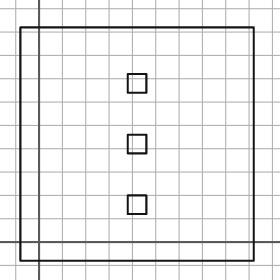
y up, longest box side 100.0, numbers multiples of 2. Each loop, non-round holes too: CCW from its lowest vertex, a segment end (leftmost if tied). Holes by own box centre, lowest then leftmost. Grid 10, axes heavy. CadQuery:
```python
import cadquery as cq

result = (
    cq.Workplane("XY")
    .moveTo(-8.0, -8.0)
    .lineTo(92.0, -8.0)
    .lineTo(92.0, 92.0)
    .lineTo(-8.0, 92.0)
    .close()
    .moveTo(38.0, 12.0)
    .lineTo(46.0, 12.0)
    .lineTo(46.0, 20.0)
    .lineTo(38.0, 20.0)
    .close()
    .moveTo(38.0, 38.0)
    .lineTo(46.0, 38.0)
    .lineTo(46.0, 46.0)
    .lineTo(38.0, 46.0)
    .close()
    .moveTo(38.0, 64.0)
    .lineTo(46.0, 64.0)
    .lineTo(46.0, 72.0)
    .lineTo(38.0, 72.0)
    .close()
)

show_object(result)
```